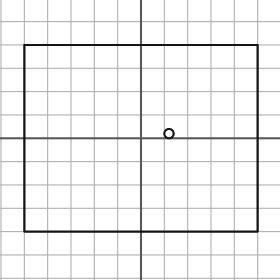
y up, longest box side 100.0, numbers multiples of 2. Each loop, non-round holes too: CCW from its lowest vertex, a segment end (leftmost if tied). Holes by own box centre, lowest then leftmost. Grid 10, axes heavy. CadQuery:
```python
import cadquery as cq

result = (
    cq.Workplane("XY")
    .moveTo(-50.0, -40.0)
    .lineTo(50.0, -40.0)
    .lineTo(50.0, 40.0)
    .lineTo(-50.0, 40.0)
    .close()
    .moveTo(12.0, 2.0)
    .circle(2.0)
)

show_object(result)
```